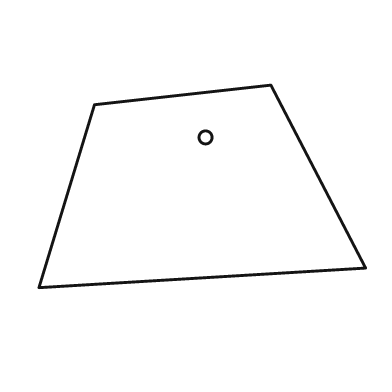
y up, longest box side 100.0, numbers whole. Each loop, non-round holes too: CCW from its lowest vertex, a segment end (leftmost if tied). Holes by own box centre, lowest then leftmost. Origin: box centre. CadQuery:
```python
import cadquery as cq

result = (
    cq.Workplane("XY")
    .moveTo(-50.0, -31.0)
    .lineTo(50.0, -25.0)
    .lineTo(21.0, 31.0)
    .lineTo(-33.0, 25.0)
    .close()
    .moveTo(1.0, 15.0)
    .circle(2.0)
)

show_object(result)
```